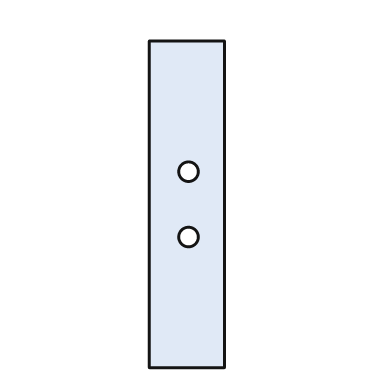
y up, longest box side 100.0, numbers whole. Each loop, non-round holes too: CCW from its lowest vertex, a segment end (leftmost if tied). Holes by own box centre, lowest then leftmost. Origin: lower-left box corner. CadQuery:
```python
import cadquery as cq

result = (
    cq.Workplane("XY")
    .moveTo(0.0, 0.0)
    .lineTo(23.0, 0.0)
    .lineTo(23.0, 100.0)
    .lineTo(0.0, 100.0)
    .close()
    .moveTo(12.0, 40.0)
    .circle(3.0)
    .moveTo(12.0, 60.0)
    .circle(3.0)
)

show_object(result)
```